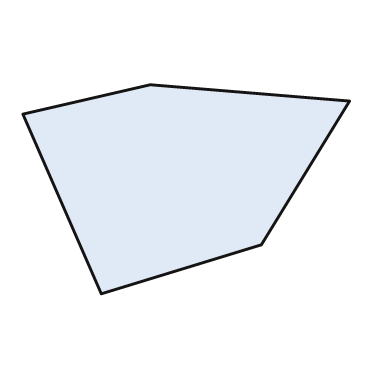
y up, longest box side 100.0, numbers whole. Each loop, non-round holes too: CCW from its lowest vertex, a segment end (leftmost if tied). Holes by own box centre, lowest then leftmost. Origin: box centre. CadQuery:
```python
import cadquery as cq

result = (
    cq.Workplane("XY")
    .moveTo(-26.0, -32.0)
    .lineTo(23.0, -17.0)
    .lineTo(50.0, 27.0)
    .lineTo(-11.0, 32.0)
    .lineTo(-50.0, 23.0)
    .close()
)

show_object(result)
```